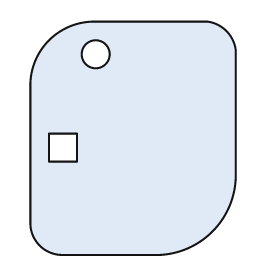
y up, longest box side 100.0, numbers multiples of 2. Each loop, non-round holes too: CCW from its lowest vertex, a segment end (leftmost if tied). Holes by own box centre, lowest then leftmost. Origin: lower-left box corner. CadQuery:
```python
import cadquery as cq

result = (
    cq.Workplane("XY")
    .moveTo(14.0, 0.0)
    .lineTo(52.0, 0.0)
    .threePointArc((78.0, 10.0), (88.0, 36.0))
    .lineTo(88.0, 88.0)
    .threePointArc((84.0, 96.0), (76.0, 100.0))
    .lineTo(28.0, 100.0)
    .threePointArc((8.0, 92.0), (0.0, 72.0))
    .lineTo(0.0, 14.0)
    .threePointArc((4.0, 4.0), (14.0, 0.0))
    .close()
    .moveTo(8.0, 40.0)
    .lineTo(20.0, 40.0)
    .lineTo(20.0, 52.0)
    .lineTo(8.0, 52.0)
    .close()
    .moveTo(28.0, 86.0)
    .circle(6.0)
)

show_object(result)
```